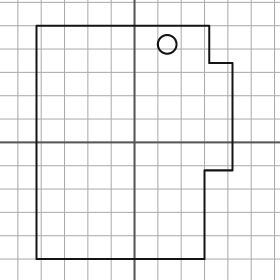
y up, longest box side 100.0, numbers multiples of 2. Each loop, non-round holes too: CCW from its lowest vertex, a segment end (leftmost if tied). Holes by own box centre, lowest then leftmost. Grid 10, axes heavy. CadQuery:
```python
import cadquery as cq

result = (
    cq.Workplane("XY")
    .moveTo(-42.0, -50.0)
    .lineTo(30.0, -50.0)
    .lineTo(30.0, -12.0)
    .lineTo(42.0, -12.0)
    .lineTo(42.0, 34.0)
    .lineTo(32.0, 34.0)
    .lineTo(32.0, 50.0)
    .lineTo(-42.0, 50.0)
    .close()
    .moveTo(14.0, 42.0)
    .circle(4.0)
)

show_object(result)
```